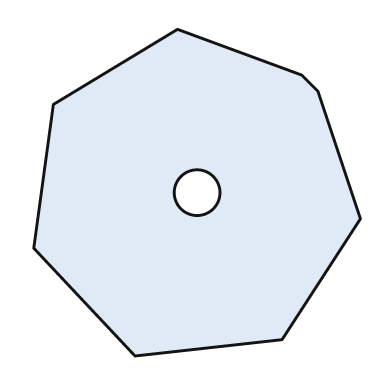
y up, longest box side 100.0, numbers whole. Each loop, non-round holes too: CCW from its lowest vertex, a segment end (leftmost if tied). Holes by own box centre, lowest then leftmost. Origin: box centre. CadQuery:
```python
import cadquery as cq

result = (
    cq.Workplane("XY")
    .moveTo(-19.0, -50.0)
    .lineTo(26.0, -45.0)
    .lineTo(50.0, -8.0)
    .lineTo(37.0, 31.0)
    .lineTo(32.0, 36.0)
    .lineTo(-6.0, 50.0)
    .lineTo(-44.0, 27.0)
    .lineTo(-50.0, -17.0)
    .close()
    .moveTo(0.0, 0.0)
    .circle(7.0)
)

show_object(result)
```